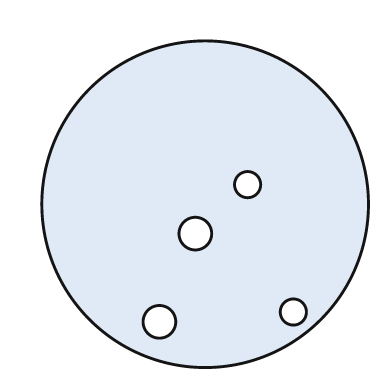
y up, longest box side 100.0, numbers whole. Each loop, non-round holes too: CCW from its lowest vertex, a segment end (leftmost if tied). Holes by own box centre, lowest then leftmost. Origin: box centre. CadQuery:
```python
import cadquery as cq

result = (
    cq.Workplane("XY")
    .moveTo(0.0, 0.0)
    .circle(50.0)
    .moveTo(-14.0, -36.0)
    .circle(5.0)
    .moveTo(27.0, -33.0)
    .circle(4.0)
    .moveTo(-3.0, -9.0)
    .circle(5.0)
    .moveTo(13.0, 6.0)
    .circle(4.0)
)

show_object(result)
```